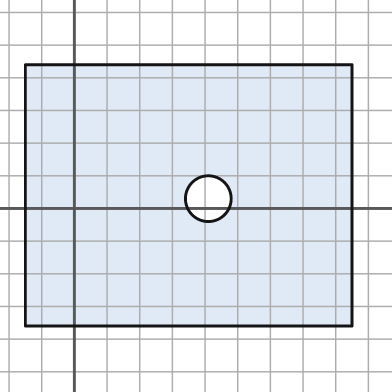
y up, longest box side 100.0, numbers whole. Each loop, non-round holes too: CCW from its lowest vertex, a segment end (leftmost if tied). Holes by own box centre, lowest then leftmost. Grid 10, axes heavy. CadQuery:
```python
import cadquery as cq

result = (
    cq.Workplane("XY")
    .moveTo(-15.0, -36.0)
    .lineTo(85.0, -36.0)
    .lineTo(85.0, 44.0)
    .lineTo(-15.0, 44.0)
    .close()
    .moveTo(41.0, 3.0)
    .circle(7.0)
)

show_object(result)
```